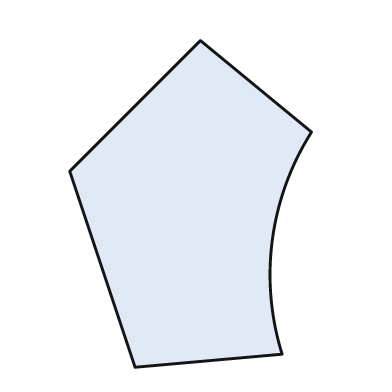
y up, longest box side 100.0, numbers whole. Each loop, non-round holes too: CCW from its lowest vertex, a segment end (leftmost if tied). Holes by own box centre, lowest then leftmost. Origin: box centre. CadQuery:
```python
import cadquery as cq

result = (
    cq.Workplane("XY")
    .moveTo(-17.0, -50.0)
    .lineTo(28.0, -46.0)
    .threePointArc((25.0, -11.0), (37.0, 22.0))
    .lineTo(3.0, 50.0)
    .lineTo(-37.0, 10.0)
    .close()
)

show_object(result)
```